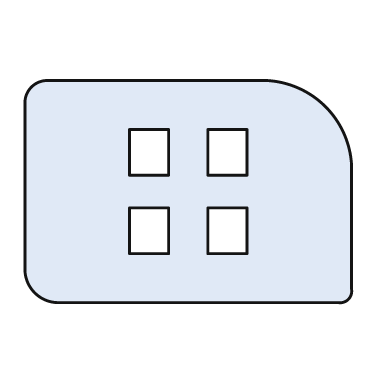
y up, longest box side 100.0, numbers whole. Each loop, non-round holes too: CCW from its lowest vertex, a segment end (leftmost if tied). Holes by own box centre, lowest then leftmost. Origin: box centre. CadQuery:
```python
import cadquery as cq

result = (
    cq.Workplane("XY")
    .moveTo(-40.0, -34.0)
    .lineTo(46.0, -34.0)
    .threePointArc((49.0, -33.0), (50.0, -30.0))
    .lineTo(50.0, 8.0)
    .threePointArc((42.0, 26.0), (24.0, 34.0))
    .lineTo(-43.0, 34.0)
    .threePointArc((-48.0, 32.0), (-50.0, 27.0))
    .lineTo(-50.0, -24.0)
    .threePointArc((-47.0, -31.0), (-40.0, -34.0))
    .close()
    .moveTo(-18.0, -19.0)
    .lineTo(-6.0, -19.0)
    .lineTo(-6.0, -5.0)
    .lineTo(-18.0, -5.0)
    .close()
    .moveTo(6.0, -19.0)
    .lineTo(18.0, -19.0)
    .lineTo(18.0, -5.0)
    .lineTo(6.0, -5.0)
    .close()
    .moveTo(-18.0, 5.0)
    .lineTo(-6.0, 5.0)
    .lineTo(-6.0, 19.0)
    .lineTo(-18.0, 19.0)
    .close()
    .moveTo(6.0, 5.0)
    .lineTo(18.0, 5.0)
    .lineTo(18.0, 19.0)
    .lineTo(6.0, 19.0)
    .close()
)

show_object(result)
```